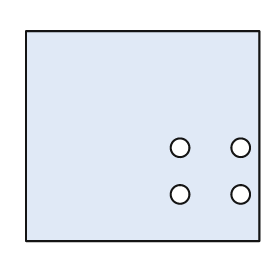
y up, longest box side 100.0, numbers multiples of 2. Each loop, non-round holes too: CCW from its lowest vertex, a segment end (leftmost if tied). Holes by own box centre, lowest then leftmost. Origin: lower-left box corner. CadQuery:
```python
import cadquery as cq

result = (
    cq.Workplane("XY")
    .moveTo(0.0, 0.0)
    .lineTo(100.0, 0.0)
    .lineTo(100.0, 90.0)
    .lineTo(0.0, 90.0)
    .close()
    .moveTo(66.0, 20.0)
    .circle(4.0)
    .moveTo(92.0, 20.0)
    .circle(4.0)
    .moveTo(66.0, 40.0)
    .circle(4.0)
    .moveTo(92.0, 40.0)
    .circle(4.0)
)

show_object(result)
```